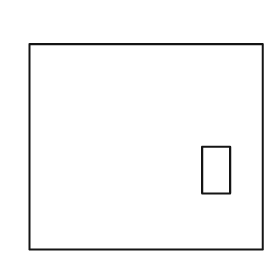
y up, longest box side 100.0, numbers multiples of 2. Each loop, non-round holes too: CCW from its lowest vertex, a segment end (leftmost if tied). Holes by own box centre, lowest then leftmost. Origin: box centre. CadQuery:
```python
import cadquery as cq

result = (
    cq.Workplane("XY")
    .moveTo(-50.0, -44.0)
    .lineTo(50.0, -44.0)
    .lineTo(50.0, 44.0)
    .lineTo(-50.0, 44.0)
    .close()
    .moveTo(24.0, -20.0)
    .lineTo(36.0, -20.0)
    .lineTo(36.0, 0.0)
    .lineTo(24.0, 0.0)
    .close()
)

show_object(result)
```